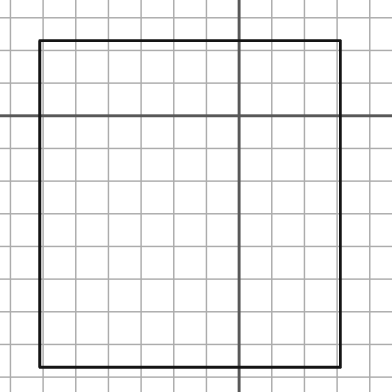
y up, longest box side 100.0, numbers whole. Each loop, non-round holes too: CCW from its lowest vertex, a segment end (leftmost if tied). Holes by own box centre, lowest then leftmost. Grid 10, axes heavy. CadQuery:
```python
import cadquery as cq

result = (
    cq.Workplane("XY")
    .moveTo(-61.0, -77.0)
    .lineTo(31.0, -77.0)
    .lineTo(31.0, 23.0)
    .lineTo(-61.0, 23.0)
    .close()
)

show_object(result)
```